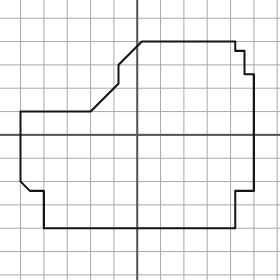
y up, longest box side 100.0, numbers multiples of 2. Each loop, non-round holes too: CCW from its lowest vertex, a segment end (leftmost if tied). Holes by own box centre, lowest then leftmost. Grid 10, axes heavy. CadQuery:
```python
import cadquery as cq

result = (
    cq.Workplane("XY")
    .moveTo(-40.0, -40.0)
    .lineTo(42.0, -40.0)
    .lineTo(42.0, -24.0)
    .lineTo(50.0, -24.0)
    .lineTo(50.0, 26.0)
    .lineTo(46.0, 26.0)
    .lineTo(46.0, 36.0)
    .lineTo(42.0, 36.0)
    .lineTo(42.0, 40.0)
    .lineTo(2.0, 40.0)
    .lineTo(-8.0, 30.0)
    .lineTo(-8.0, 22.0)
    .lineTo(-20.0, 10.0)
    .lineTo(-50.0, 10.0)
    .lineTo(-50.0, -20.0)
    .lineTo(-46.0, -24.0)
    .lineTo(-40.0, -24.0)
    .close()
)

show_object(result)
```